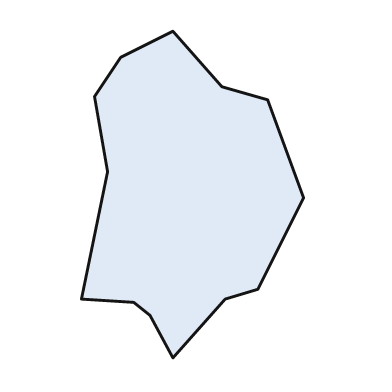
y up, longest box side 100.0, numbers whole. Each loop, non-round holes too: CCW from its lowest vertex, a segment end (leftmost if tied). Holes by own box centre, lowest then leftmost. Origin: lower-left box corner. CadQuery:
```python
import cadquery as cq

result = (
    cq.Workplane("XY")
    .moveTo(28.0, 0.0)
    .lineTo(44.0, 18.0)
    .lineTo(54.0, 21.0)
    .lineTo(68.0, 49.0)
    .lineTo(57.0, 79.0)
    .lineTo(43.0, 83.0)
    .lineTo(28.0, 100.0)
    .lineTo(12.0, 92.0)
    .lineTo(4.0, 80.0)
    .lineTo(8.0, 57.0)
    .lineTo(0.0, 18.0)
    .lineTo(16.0, 17.0)
    .lineTo(21.0, 13.0)
    .close()
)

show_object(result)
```